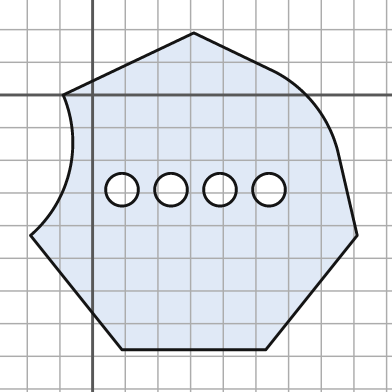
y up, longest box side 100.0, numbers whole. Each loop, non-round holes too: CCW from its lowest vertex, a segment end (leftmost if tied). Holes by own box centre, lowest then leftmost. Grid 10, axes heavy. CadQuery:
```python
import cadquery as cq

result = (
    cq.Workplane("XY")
    .moveTo(9.0, -78.0)
    .lineTo(53.0, -78.0)
    .lineTo(81.0, -43.0)
    .lineTo(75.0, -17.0)
    .threePointArc((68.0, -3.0), (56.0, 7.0))
    .lineTo(31.0, 19.0)
    .lineTo(-9.0, 0.0)
    .threePointArc((-7.0, -23.0), (-19.0, -43.0))
    .close()
    .moveTo(9.0, -29.0)
    .circle(5.0)
    .moveTo(24.0, -29.0)
    .circle(5.0)
    .moveTo(39.0, -29.0)
    .circle(5.0)
    .moveTo(54.0, -29.0)
    .circle(5.0)
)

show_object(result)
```